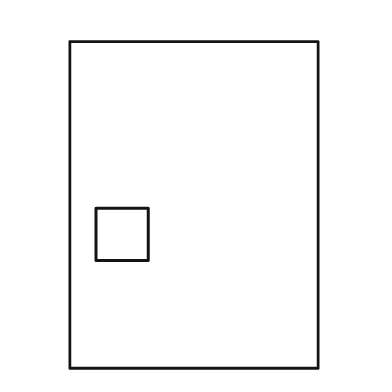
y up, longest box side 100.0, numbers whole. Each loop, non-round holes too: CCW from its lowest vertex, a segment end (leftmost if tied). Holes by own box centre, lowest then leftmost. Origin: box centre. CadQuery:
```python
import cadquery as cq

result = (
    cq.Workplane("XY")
    .moveTo(-38.0, -50.0)
    .lineTo(38.0, -50.0)
    .lineTo(38.0, 50.0)
    .lineTo(-38.0, 50.0)
    .close()
    .moveTo(-30.0, -17.0)
    .lineTo(-14.0, -17.0)
    .lineTo(-14.0, -1.0)
    .lineTo(-30.0, -1.0)
    .close()
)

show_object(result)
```